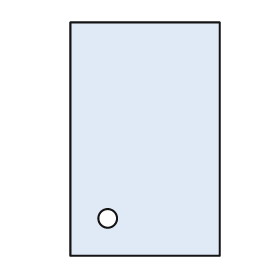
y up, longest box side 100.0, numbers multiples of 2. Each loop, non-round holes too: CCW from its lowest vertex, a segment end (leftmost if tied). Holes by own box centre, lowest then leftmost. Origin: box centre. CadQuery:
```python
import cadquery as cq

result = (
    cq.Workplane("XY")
    .moveTo(-32.0, -50.0)
    .lineTo(32.0, -50.0)
    .lineTo(32.0, 50.0)
    .lineTo(-32.0, 50.0)
    .close()
    .moveTo(-16.0, -34.0)
    .circle(4.0)
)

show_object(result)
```